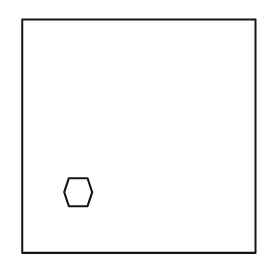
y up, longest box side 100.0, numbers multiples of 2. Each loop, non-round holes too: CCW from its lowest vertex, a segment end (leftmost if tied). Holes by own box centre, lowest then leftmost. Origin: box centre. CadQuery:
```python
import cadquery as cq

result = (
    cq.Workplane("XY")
    .moveTo(-50.0, -50.0)
    .lineTo(50.0, -50.0)
    .lineTo(50.0, 50.0)
    .lineTo(-50.0, 50.0)
    .close()
    .moveTo(-30.0, -30.0)
    .lineTo(-22.0, -30.0)
    .lineTo(-20.0, -24.0)
    .lineTo(-22.0, -18.0)
    .lineTo(-30.0, -18.0)
    .lineTo(-32.0, -24.0)
    .close()
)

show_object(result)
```